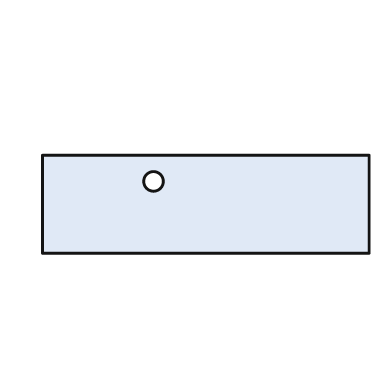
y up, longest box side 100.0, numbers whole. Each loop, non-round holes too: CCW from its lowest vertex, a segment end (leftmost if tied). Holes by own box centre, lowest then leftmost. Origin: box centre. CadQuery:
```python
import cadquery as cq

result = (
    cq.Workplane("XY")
    .moveTo(-50.0, -15.0)
    .lineTo(50.0, -15.0)
    .lineTo(50.0, 15.0)
    .lineTo(-50.0, 15.0)
    .close()
    .moveTo(-16.0, 7.0)
    .circle(3.0)
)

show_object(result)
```